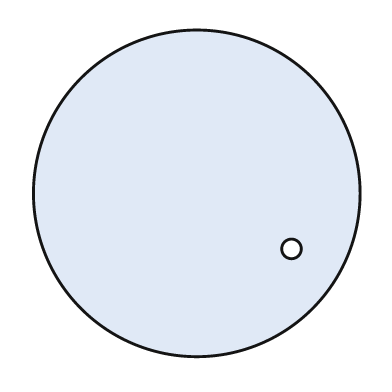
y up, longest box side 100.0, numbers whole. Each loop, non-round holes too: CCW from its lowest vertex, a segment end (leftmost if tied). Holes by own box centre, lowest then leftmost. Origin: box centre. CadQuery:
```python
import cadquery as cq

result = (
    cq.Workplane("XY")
    .moveTo(0.0, 0.0)
    .circle(50.0)
    .moveTo(29.0, -17.0)
    .circle(3.0)
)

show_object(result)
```